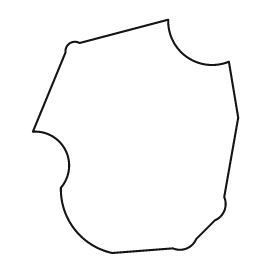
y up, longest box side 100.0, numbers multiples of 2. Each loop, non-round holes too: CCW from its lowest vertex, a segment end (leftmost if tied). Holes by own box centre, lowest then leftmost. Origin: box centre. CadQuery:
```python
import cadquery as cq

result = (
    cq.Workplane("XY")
    .moveTo(-10.0, -50.0)
    .lineTo(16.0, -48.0)
    .threePointArc((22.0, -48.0), (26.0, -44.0))
    .lineTo(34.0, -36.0)
    .threePointArc((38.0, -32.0), (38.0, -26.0))
    .lineTo(44.0, 8.0)
    .lineTo(40.0, 32.0)
    .threePointArc((22.0, 34.0), (14.0, 50.0))
    .lineTo(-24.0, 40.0)
    .threePointArc((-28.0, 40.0), (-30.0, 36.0))
    .lineTo(-44.0, 2.0)
    .threePointArc((-30.0, -6.0), (-32.0, -22.0))
    .threePointArc((-26.0, -40.0), (-10.0, -50.0))
    .close()
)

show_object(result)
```